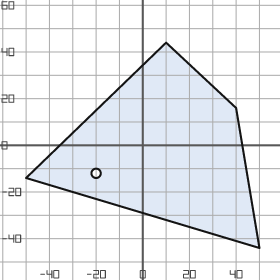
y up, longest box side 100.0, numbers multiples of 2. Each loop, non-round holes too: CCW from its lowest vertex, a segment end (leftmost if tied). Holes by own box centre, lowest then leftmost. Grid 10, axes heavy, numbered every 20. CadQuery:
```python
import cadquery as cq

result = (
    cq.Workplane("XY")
    .moveTo(50.0, -44.0)
    .lineTo(40.0, 16.0)
    .lineTo(10.0, 44.0)
    .lineTo(-50.0, -14.0)
    .close()
    .moveTo(-20.0, -12.0)
    .circle(2.0)
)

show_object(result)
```